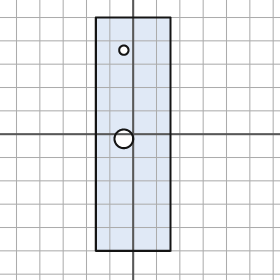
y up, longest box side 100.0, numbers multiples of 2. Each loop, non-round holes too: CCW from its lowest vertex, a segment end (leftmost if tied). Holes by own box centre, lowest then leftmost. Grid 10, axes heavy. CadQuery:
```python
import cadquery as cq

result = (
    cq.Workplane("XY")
    .moveTo(-16.0, -50.0)
    .lineTo(16.0, -50.0)
    .lineTo(16.0, 50.0)
    .lineTo(-16.0, 50.0)
    .close()
    .moveTo(-4.0, -2.0)
    .circle(4.0)
    .moveTo(-4.0, 36.0)
    .circle(2.0)
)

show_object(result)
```